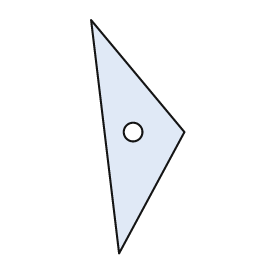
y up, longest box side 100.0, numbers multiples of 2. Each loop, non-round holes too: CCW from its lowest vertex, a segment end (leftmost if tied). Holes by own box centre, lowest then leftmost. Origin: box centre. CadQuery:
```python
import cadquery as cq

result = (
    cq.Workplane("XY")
    .moveTo(-8.0, -50.0)
    .lineTo(20.0, 2.0)
    .lineTo(-20.0, 50.0)
    .close()
    .moveTo(-2.0, 2.0)
    .circle(4.0)
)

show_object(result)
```